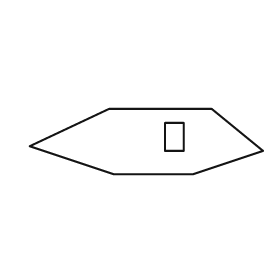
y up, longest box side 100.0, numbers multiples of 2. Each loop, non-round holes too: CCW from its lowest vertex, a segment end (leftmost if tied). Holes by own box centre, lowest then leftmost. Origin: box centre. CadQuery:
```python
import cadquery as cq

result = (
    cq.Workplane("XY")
    .moveTo(-14.0, -14.0)
    .lineTo(20.0, -14.0)
    .lineTo(50.0, -4.0)
    .lineTo(28.0, 14.0)
    .lineTo(-16.0, 14.0)
    .lineTo(-50.0, -2.0)
    .close()
    .moveTo(8.0, -4.0)
    .lineTo(16.0, -4.0)
    .lineTo(16.0, 8.0)
    .lineTo(8.0, 8.0)
    .close()
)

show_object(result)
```